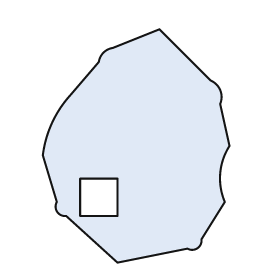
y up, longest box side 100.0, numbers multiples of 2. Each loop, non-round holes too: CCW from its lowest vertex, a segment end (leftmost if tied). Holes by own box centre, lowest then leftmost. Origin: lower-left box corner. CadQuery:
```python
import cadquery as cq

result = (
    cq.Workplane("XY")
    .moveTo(32.0, 0.0)
    .lineTo(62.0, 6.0)
    .threePointArc((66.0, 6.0), (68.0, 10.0))
    .lineTo(78.0, 26.0)
    .threePointArc((76.0, 38.0), (80.0, 50.0))
    .lineTo(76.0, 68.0)
    .threePointArc((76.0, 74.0), (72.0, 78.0))
    .lineTo(50.0, 100.0)
    .lineTo(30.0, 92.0)
    .threePointArc((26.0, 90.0), (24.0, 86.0))
    .lineTo(12.0, 72.0)
    .threePointArc((4.0, 60.0), (0.0, 46.0))
    .lineTo(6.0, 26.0)
    .threePointArc((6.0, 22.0), (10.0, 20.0))
    .close()
    .moveTo(16.0, 20.0)
    .lineTo(32.0, 20.0)
    .lineTo(32.0, 36.0)
    .lineTo(16.0, 36.0)
    .close()
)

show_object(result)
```